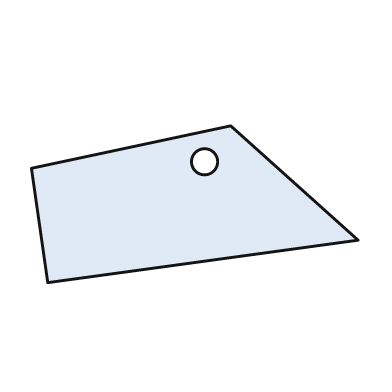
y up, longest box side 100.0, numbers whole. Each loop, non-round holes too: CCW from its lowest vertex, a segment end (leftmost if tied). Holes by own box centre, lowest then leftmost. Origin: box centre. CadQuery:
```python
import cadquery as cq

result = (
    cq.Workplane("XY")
    .moveTo(-45.0, -24.0)
    .lineTo(50.0, -11.0)
    .lineTo(11.0, 24.0)
    .lineTo(-50.0, 11.0)
    .close()
    .moveTo(3.0, 13.0)
    .circle(4.0)
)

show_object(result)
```